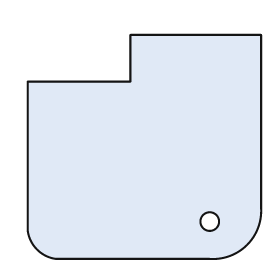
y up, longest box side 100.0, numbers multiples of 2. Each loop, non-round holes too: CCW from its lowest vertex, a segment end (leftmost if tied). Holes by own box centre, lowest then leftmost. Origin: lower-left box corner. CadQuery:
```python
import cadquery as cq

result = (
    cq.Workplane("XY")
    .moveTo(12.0, 0.0)
    .lineTo(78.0, 0.0)
    .threePointArc((94.0, 6.0), (100.0, 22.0))
    .lineTo(100.0, 96.0)
    .lineTo(44.0, 96.0)
    .lineTo(44.0, 76.0)
    .lineTo(0.0, 76.0)
    .lineTo(0.0, 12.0)
    .threePointArc((4.0, 4.0), (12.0, 0.0))
    .close()
    .moveTo(78.0, 16.0)
    .circle(4.0)
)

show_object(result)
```